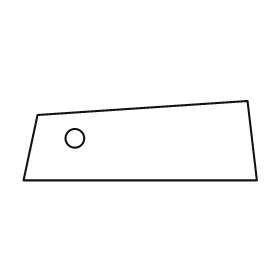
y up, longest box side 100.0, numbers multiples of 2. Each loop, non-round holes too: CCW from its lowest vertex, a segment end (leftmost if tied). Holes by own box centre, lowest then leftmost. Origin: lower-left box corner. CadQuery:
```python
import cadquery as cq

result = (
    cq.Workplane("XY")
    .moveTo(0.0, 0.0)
    .lineTo(100.0, 0.0)
    .lineTo(96.0, 34.0)
    .lineTo(6.0, 28.0)
    .close()
    .moveTo(22.0, 18.0)
    .circle(4.0)
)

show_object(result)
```